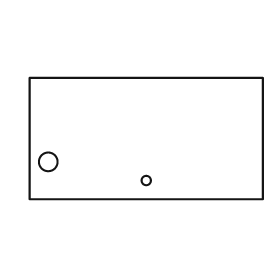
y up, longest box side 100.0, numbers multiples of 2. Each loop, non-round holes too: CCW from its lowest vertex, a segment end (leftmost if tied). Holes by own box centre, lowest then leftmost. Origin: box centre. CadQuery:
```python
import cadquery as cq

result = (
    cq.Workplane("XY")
    .moveTo(-50.0, -26.0)
    .lineTo(50.0, -26.0)
    .lineTo(50.0, 26.0)
    .lineTo(-50.0, 26.0)
    .close()
    .moveTo(0.0, -18.0)
    .circle(2.0)
    .moveTo(-42.0, -10.0)
    .circle(4.0)
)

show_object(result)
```